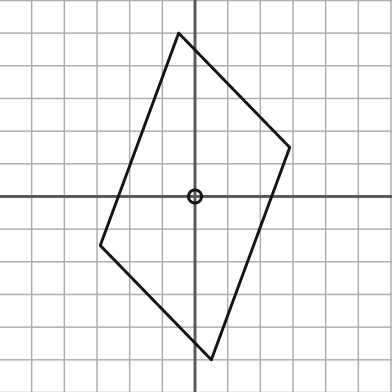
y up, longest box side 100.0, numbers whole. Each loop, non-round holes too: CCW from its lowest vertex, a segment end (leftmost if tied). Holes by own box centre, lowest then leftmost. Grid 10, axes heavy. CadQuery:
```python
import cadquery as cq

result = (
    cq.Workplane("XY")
    .moveTo(5.0, -50.0)
    .lineTo(29.0, 15.0)
    .lineTo(-5.0, 50.0)
    .lineTo(-29.0, -15.0)
    .close()
    .moveTo(0.0, 0.0)
    .circle(2.0)
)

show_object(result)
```